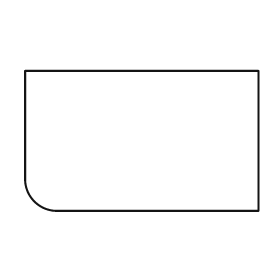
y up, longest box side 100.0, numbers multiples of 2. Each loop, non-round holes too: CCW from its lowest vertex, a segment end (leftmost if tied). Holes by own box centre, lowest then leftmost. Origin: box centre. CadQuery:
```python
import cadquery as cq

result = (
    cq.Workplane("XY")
    .moveTo(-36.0, -30.0)
    .lineTo(50.0, -30.0)
    .lineTo(50.0, 30.0)
    .lineTo(-50.0, 30.0)
    .lineTo(-50.0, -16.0)
    .threePointArc((-46.0, -26.0), (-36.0, -30.0))
    .close()
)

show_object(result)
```